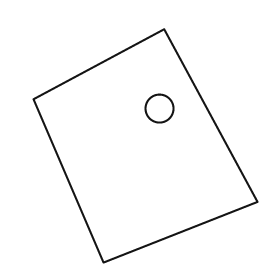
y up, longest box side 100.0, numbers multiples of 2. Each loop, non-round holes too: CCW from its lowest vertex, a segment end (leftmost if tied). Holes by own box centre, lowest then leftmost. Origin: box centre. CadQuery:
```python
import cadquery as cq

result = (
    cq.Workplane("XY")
    .moveTo(-18.0, -50.0)
    .lineTo(48.0, -24.0)
    .lineTo(8.0, 50.0)
    .lineTo(-48.0, 20.0)
    .close()
    .moveTo(6.0, 16.0)
    .circle(6.0)
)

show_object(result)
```